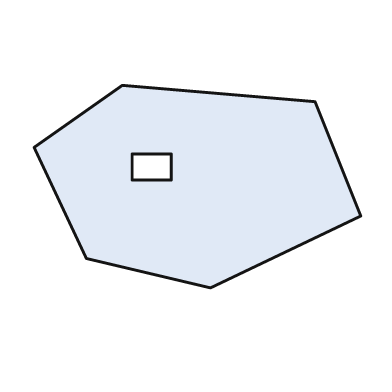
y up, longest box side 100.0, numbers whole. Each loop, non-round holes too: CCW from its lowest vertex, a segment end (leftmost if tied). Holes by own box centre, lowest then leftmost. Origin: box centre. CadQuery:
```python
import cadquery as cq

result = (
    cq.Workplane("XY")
    .moveTo(4.0, -31.0)
    .lineTo(50.0, -9.0)
    .lineTo(36.0, 26.0)
    .lineTo(-23.0, 31.0)
    .lineTo(-50.0, 12.0)
    .lineTo(-34.0, -22.0)
    .close()
    .moveTo(-20.0, 2.0)
    .lineTo(-8.0, 2.0)
    .lineTo(-8.0, 10.0)
    .lineTo(-20.0, 10.0)
    .close()
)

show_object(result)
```